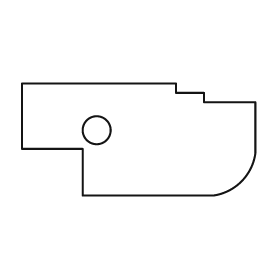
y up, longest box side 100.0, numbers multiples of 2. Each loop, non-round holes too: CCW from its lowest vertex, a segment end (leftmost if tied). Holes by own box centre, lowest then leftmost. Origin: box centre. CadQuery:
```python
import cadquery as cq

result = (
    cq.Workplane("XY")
    .moveTo(-24.0, -24.0)
    .lineTo(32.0, -24.0)
    .threePointArc((44.0, -18.0), (50.0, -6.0))
    .lineTo(50.0, 16.0)
    .lineTo(28.0, 16.0)
    .lineTo(28.0, 20.0)
    .lineTo(16.0, 20.0)
    .lineTo(16.0, 24.0)
    .lineTo(-50.0, 24.0)
    .lineTo(-50.0, -4.0)
    .lineTo(-24.0, -4.0)
    .close()
    .moveTo(-18.0, 4.0)
    .circle(6.0)
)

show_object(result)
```